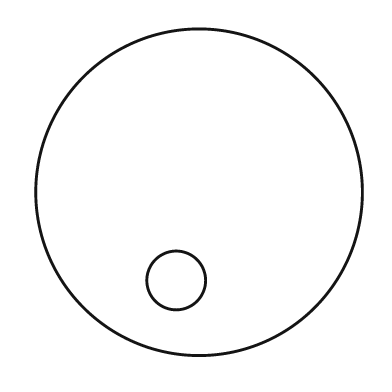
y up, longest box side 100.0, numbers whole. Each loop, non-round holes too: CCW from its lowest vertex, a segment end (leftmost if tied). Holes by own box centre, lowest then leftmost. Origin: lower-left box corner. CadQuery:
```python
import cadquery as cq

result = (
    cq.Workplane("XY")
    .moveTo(50.0, 50.0)
    .circle(50.0)
    .moveTo(43.0, 23.0)
    .circle(9.0)
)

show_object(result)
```